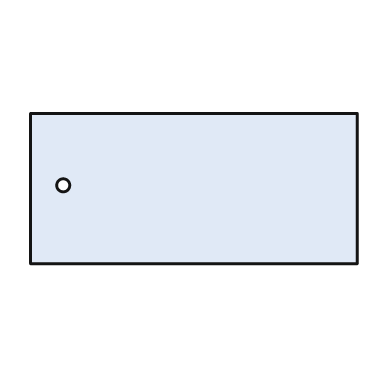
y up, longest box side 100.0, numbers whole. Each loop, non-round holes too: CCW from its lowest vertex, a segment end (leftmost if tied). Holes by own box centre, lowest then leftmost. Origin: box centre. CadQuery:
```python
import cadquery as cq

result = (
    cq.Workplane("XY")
    .moveTo(-50.0, -23.0)
    .lineTo(50.0, -23.0)
    .lineTo(50.0, 23.0)
    .lineTo(-50.0, 23.0)
    .close()
    .moveTo(-40.0, 1.0)
    .circle(2.0)
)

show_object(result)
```